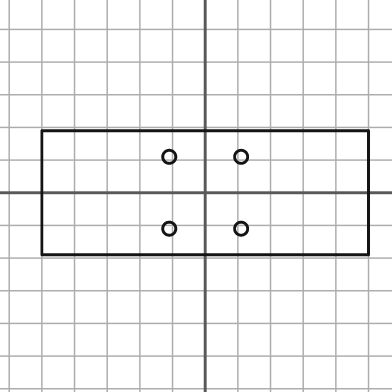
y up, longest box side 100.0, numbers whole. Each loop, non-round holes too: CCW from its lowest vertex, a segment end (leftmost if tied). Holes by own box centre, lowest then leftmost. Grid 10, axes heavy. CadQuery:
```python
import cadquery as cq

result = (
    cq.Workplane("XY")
    .moveTo(-50.0, -19.0)
    .lineTo(50.0, -19.0)
    .lineTo(50.0, 19.0)
    .lineTo(-50.0, 19.0)
    .close()
    .moveTo(-11.0, -11.0)
    .circle(2.0)
    .moveTo(11.0, -11.0)
    .circle(2.0)
    .moveTo(-11.0, 11.0)
    .circle(2.0)
    .moveTo(11.0, 11.0)
    .circle(2.0)
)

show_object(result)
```